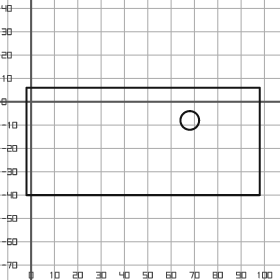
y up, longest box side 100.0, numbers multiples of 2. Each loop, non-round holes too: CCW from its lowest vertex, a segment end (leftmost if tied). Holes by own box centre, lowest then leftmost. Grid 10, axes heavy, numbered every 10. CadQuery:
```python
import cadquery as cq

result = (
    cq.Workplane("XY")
    .moveTo(-2.0, -40.0)
    .lineTo(98.0, -40.0)
    .lineTo(98.0, 6.0)
    .lineTo(-2.0, 6.0)
    .close()
    .moveTo(68.0, -8.0)
    .circle(4.0)
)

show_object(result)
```